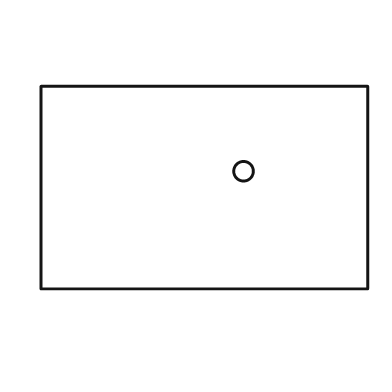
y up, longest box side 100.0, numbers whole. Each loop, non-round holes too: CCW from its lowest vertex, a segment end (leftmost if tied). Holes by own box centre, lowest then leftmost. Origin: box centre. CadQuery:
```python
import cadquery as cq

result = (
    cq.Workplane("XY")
    .moveTo(-50.0, -31.0)
    .lineTo(50.0, -31.0)
    .lineTo(50.0, 31.0)
    .lineTo(-50.0, 31.0)
    .close()
    .moveTo(12.0, 5.0)
    .circle(3.0)
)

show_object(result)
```